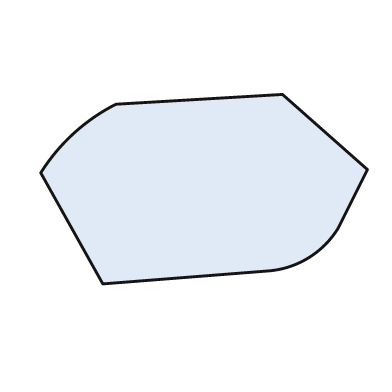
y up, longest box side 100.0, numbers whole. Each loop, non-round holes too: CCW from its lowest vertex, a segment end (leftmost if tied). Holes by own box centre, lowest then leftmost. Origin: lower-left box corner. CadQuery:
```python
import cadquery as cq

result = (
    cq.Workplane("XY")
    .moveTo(19.0, 0.0)
    .lineTo(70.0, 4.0)
    .threePointArc((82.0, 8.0), (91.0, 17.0))
    .lineTo(100.0, 35.0)
    .lineTo(74.0, 58.0)
    .lineTo(23.0, 55.0)
    .threePointArc((10.0, 46.0), (0.0, 34.0))
    .close()
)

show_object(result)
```